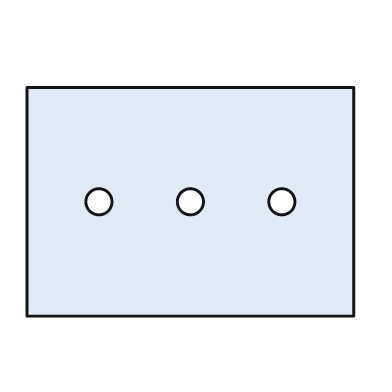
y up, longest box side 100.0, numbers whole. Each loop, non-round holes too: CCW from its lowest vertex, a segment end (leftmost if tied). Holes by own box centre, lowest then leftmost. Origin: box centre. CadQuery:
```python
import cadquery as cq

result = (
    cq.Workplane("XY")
    .moveTo(-50.0, -35.0)
    .lineTo(50.0, -35.0)
    .lineTo(50.0, 35.0)
    .lineTo(-50.0, 35.0)
    .close()
    .moveTo(-28.0, 0.0)
    .circle(4.0)
    .moveTo(0.0, 0.0)
    .circle(4.0)
    .moveTo(28.0, 0.0)
    .circle(4.0)
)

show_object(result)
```